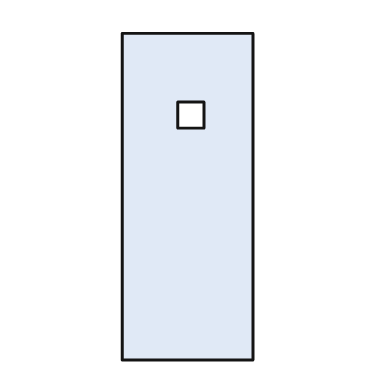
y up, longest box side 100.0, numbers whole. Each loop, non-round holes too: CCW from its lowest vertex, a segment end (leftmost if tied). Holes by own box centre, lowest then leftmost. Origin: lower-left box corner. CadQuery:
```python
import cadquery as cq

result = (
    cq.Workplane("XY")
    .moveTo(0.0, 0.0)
    .lineTo(40.0, 0.0)
    .lineTo(40.0, 100.0)
    .lineTo(0.0, 100.0)
    .close()
    .moveTo(17.0, 71.0)
    .lineTo(25.0, 71.0)
    .lineTo(25.0, 79.0)
    .lineTo(17.0, 79.0)
    .close()
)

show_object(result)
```